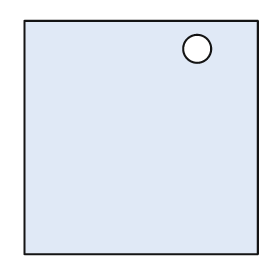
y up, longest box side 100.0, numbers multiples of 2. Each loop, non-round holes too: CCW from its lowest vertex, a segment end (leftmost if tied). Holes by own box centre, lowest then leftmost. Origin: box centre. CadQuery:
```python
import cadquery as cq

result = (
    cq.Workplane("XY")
    .moveTo(-50.0, -50.0)
    .lineTo(50.0, -50.0)
    .lineTo(50.0, 50.0)
    .lineTo(-50.0, 50.0)
    .close()
    .moveTo(24.0, 38.0)
    .circle(6.0)
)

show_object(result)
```